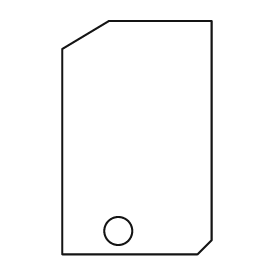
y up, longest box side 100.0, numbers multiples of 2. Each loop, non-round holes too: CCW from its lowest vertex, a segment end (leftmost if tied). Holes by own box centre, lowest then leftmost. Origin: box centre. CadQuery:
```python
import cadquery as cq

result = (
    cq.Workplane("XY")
    .moveTo(-32.0, -50.0)
    .lineTo(26.0, -50.0)
    .lineTo(32.0, -44.0)
    .lineTo(32.0, 50.0)
    .lineTo(-12.0, 50.0)
    .lineTo(-32.0, 38.0)
    .close()
    .moveTo(-8.0, -40.0)
    .circle(6.0)
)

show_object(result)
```